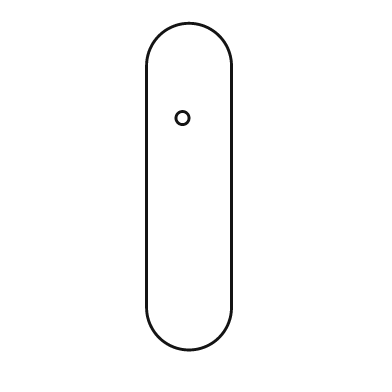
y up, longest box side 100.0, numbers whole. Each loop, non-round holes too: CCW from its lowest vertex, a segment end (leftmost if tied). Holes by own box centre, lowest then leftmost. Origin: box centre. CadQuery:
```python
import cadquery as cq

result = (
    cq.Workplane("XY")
    .moveTo(-13.0, -37.0)
    .threePointArc((0.0, -50.0), (13.0, -37.0))
    .lineTo(13.0, 37.0)
    .threePointArc((0.0, 50.0), (-13.0, 37.0))
    .close()
    .moveTo(-2.0, 21.0)
    .circle(2.0)
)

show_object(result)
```